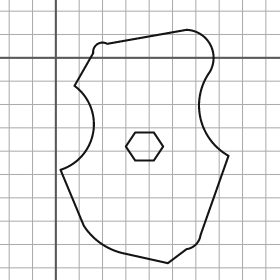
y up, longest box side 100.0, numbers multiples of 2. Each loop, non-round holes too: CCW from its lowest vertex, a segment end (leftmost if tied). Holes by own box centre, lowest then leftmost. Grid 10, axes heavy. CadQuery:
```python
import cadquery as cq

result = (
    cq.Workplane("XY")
    .moveTo(48.0, -88.0)
    .lineTo(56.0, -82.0)
    .threePointArc((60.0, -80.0), (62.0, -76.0))
    .lineTo(74.0, -42.0)
    .threePointArc((62.0, -26.0), (66.0, -6.0))
    .threePointArc((66.0, 6.0), (56.0, 12.0))
    .lineTo(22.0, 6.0)
    .threePointArc((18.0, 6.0), (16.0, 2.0))
    .lineTo(8.0, -12.0)
    .threePointArc((16.0, -32.0), (2.0, -48.0))
    .lineTo(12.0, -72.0)
    .threePointArc((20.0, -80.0), (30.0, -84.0))
    .close()
    .moveTo(34.0, -44.0)
    .lineTo(42.0, -44.0)
    .lineTo(46.0, -38.0)
    .lineTo(42.0, -32.0)
    .lineTo(34.0, -32.0)
    .lineTo(30.0, -38.0)
    .close()
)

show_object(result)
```